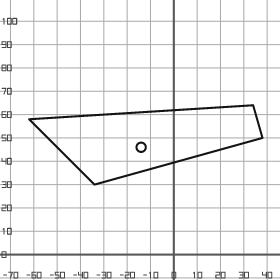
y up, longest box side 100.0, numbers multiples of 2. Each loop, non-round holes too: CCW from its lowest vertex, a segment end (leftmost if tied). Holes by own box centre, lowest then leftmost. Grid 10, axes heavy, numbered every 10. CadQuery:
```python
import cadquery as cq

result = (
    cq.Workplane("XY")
    .moveTo(-34.0, 30.0)
    .lineTo(38.0, 50.0)
    .lineTo(34.0, 64.0)
    .lineTo(-62.0, 58.0)
    .close()
    .moveTo(-14.0, 46.0)
    .circle(2.0)
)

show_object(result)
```